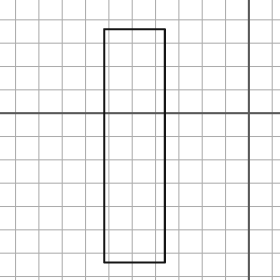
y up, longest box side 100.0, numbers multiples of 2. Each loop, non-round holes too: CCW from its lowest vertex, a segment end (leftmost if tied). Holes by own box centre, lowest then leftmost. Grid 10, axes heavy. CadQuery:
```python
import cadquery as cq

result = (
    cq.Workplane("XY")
    .moveTo(-62.0, -64.0)
    .lineTo(-36.0, -64.0)
    .lineTo(-36.0, 36.0)
    .lineTo(-62.0, 36.0)
    .close()
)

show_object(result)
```